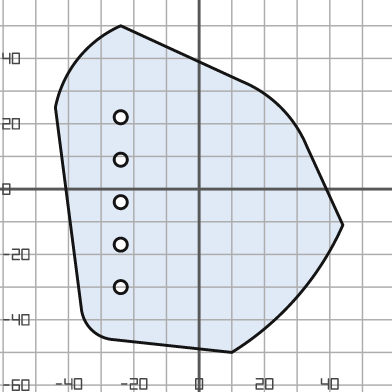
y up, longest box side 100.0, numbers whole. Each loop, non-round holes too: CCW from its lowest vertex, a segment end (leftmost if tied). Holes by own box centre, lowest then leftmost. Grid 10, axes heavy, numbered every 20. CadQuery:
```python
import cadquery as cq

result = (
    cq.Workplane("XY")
    .moveTo(10.0, -50.0)
    .threePointArc((30.0, -33.0), (44.0, -11.0))
    .lineTo(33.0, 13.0)
    .threePointArc((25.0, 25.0), (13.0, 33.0))
    .lineTo(-24.0, 50.0)
    .threePointArc((-37.0, 40.0), (-44.0, 25.0))
    .lineTo(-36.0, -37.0)
    .threePointArc((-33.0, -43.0), (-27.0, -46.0))
    .close()
    .moveTo(-24.0, -30.0)
    .circle(2.0)
    .moveTo(-24.0, -17.0)
    .circle(2.0)
    .moveTo(-24.0, -4.0)
    .circle(2.0)
    .moveTo(-24.0, 9.0)
    .circle(2.0)
    .moveTo(-24.0, 22.0)
    .circle(2.0)
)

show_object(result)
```